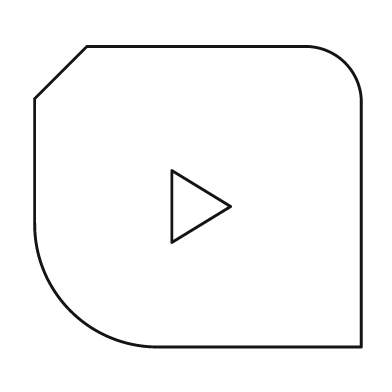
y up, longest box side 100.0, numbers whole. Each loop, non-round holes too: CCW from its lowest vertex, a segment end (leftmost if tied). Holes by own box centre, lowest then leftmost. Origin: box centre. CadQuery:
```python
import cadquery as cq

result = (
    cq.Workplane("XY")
    .moveTo(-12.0, -46.0)
    .lineTo(50.0, -46.0)
    .lineTo(50.0, 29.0)
    .threePointArc((45.0, 41.0), (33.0, 46.0))
    .lineTo(-34.0, 46.0)
    .lineTo(-50.0, 30.0)
    .lineTo(-50.0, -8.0)
    .threePointArc((-39.0, -35.0), (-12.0, -46.0))
    .close()
    .moveTo(-8.0, -14.0)
    .lineTo(10.0, -3.0)
    .lineTo(-8.0, 8.0)
    .close()
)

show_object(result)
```